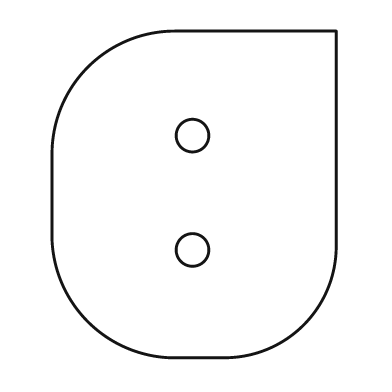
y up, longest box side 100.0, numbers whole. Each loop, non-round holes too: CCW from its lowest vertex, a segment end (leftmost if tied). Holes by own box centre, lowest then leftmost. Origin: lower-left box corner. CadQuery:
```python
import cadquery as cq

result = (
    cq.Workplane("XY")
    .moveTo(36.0, 0.0)
    .lineTo(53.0, 0.0)
    .threePointArc((77.0, 10.0), (87.0, 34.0))
    .lineTo(87.0, 100.0)
    .lineTo(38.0, 100.0)
    .threePointArc((11.0, 89.0), (0.0, 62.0))
    .lineTo(0.0, 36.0)
    .threePointArc((11.0, 11.0), (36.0, 0.0))
    .close()
    .moveTo(43.0, 33.0)
    .circle(5.0)
    .moveTo(43.0, 68.0)
    .circle(5.0)
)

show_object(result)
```